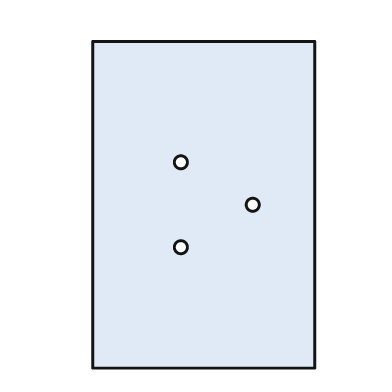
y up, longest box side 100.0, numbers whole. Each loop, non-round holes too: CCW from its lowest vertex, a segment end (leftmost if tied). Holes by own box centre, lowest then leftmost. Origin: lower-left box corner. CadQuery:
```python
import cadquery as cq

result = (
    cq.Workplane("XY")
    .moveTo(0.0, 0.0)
    .lineTo(68.0, 0.0)
    .lineTo(68.0, 100.0)
    .lineTo(0.0, 100.0)
    .close()
    .moveTo(27.0, 37.0)
    .circle(2.0)
    .moveTo(49.0, 50.0)
    .circle(2.0)
    .moveTo(27.0, 63.0)
    .circle(2.0)
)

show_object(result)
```